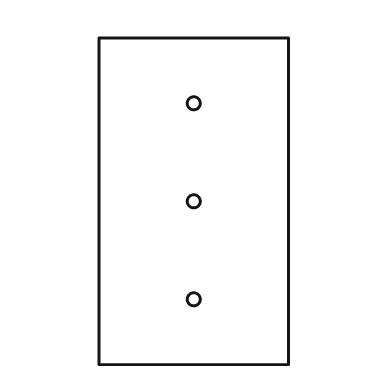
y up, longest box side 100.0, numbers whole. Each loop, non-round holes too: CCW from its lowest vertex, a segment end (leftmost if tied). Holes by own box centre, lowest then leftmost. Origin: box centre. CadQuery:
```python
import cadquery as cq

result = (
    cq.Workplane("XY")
    .moveTo(-29.0, -50.0)
    .lineTo(29.0, -50.0)
    .lineTo(29.0, 50.0)
    .lineTo(-29.0, 50.0)
    .close()
    .moveTo(0.0, -30.0)
    .circle(2.0)
    .moveTo(0.0, 0.0)
    .circle(2.0)
    .moveTo(0.0, 30.0)
    .circle(2.0)
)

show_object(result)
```